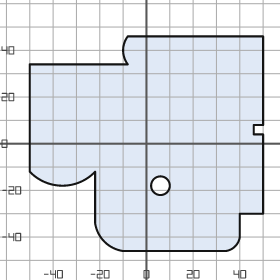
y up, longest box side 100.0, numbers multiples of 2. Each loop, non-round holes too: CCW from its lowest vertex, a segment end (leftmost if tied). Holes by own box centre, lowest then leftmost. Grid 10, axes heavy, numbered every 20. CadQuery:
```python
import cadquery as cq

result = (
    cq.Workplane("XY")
    .moveTo(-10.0, -46.0)
    .lineTo(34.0, -46.0)
    .threePointArc((38.0, -44.0), (40.0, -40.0))
    .lineTo(40.0, -30.0)
    .lineTo(50.0, -30.0)
    .lineTo(50.0, 4.0)
    .lineTo(46.0, 4.0)
    .lineTo(46.0, 8.0)
    .lineTo(50.0, 8.0)
    .lineTo(50.0, 46.0)
    .lineTo(-8.0, 46.0)
    .threePointArc((-10.0, 40.0), (-8.0, 34.0))
    .lineTo(-50.0, 34.0)
    .lineTo(-50.0, -12.0)
    .threePointArc((-36.0, -18.0), (-22.0, -12.0))
    .lineTo(-22.0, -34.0)
    .threePointArc((-18.0, -42.0), (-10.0, -46.0))
    .close()
    .moveTo(6.0, -18.0)
    .circle(4.0)
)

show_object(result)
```